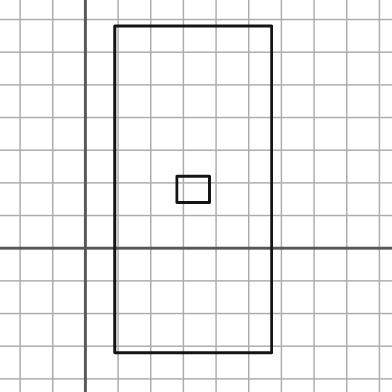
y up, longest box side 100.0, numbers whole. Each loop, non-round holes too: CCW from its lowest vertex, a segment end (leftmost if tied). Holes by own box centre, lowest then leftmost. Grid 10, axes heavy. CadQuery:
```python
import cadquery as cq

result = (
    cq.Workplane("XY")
    .moveTo(9.0, -32.0)
    .lineTo(57.0, -32.0)
    .lineTo(57.0, 68.0)
    .lineTo(9.0, 68.0)
    .close()
    .moveTo(28.0, 14.0)
    .lineTo(38.0, 14.0)
    .lineTo(38.0, 22.0)
    .lineTo(28.0, 22.0)
    .close()
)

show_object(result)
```